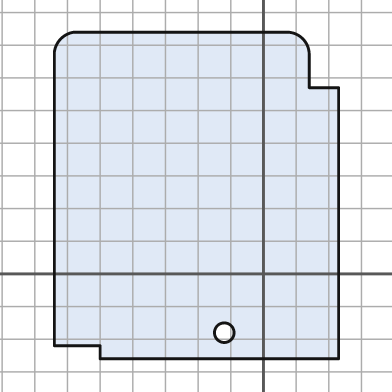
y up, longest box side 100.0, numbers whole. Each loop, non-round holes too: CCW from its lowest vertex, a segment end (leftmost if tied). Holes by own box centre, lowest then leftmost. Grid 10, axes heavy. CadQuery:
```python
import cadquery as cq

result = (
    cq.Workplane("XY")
    .moveTo(-50.0, -26.0)
    .lineTo(23.0, -26.0)
    .lineTo(23.0, 57.0)
    .lineTo(14.0, 57.0)
    .lineTo(14.0, 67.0)
    .threePointArc((12.0, 72.0), (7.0, 74.0))
    .lineTo(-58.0, 74.0)
    .threePointArc((-62.0, 72.0), (-64.0, 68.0))
    .lineTo(-64.0, -22.0)
    .lineTo(-50.0, -22.0)
    .close()
    .moveTo(-12.0, -18.0)
    .circle(3.0)
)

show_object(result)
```